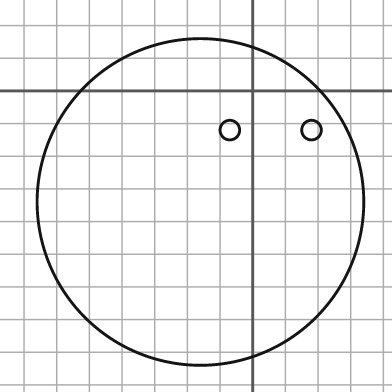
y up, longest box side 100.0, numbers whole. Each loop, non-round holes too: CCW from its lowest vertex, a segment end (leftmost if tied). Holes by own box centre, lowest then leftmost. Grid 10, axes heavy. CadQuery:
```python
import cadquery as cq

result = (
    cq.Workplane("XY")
    .moveTo(-16.0, -34.0)
    .circle(50.0)
    .moveTo(-7.0, -12.0)
    .circle(3.0)
    .moveTo(18.0, -12.0)
    .circle(3.0)
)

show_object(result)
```